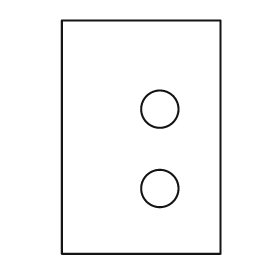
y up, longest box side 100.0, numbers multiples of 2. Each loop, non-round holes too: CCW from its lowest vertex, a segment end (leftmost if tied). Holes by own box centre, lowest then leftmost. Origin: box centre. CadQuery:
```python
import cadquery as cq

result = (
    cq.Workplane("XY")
    .moveTo(-34.0, -50.0)
    .lineTo(34.0, -50.0)
    .lineTo(34.0, 50.0)
    .lineTo(-34.0, 50.0)
    .close()
    .moveTo(8.0, -22.0)
    .circle(8.0)
    .moveTo(8.0, 12.0)
    .circle(8.0)
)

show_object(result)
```